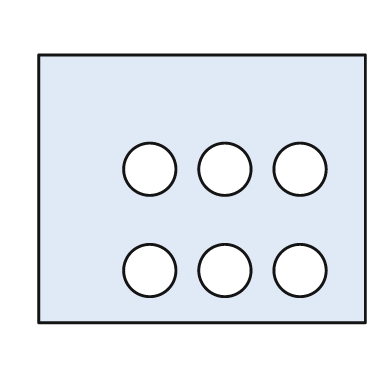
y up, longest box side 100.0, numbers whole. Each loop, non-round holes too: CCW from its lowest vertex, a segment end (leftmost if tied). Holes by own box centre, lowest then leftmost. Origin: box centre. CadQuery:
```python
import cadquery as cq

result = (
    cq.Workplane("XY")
    .moveTo(-50.0, -41.0)
    .lineTo(50.0, -41.0)
    .lineTo(50.0, 41.0)
    .lineTo(-50.0, 41.0)
    .close()
    .moveTo(-16.0, -25.0)
    .circle(8.0)
    .moveTo(7.0, -25.0)
    .circle(8.0)
    .moveTo(30.0, -25.0)
    .circle(8.0)
    .moveTo(-16.0, 6.0)
    .circle(8.0)
    .moveTo(7.0, 6.0)
    .circle(8.0)
    .moveTo(30.0, 6.0)
    .circle(8.0)
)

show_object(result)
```